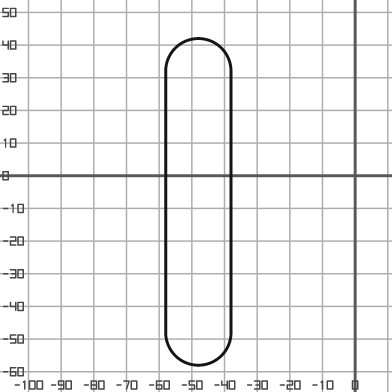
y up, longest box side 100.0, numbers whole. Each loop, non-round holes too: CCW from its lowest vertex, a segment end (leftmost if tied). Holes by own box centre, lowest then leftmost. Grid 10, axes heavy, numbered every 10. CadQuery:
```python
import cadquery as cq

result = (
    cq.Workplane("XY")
    .moveTo(-58.0, -48.0)
    .threePointArc((-48.0, -58.0), (-38.0, -48.0))
    .lineTo(-38.0, 32.0)
    .threePointArc((-48.0, 42.0), (-58.0, 32.0))
    .close()
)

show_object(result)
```